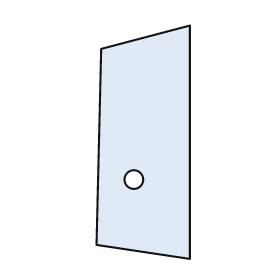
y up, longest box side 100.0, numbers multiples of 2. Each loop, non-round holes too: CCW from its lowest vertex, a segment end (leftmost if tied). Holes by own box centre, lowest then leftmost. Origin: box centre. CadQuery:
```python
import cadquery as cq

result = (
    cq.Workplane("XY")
    .moveTo(20.0, -50.0)
    .lineTo(20.0, 50.0)
    .lineTo(-18.0, 40.0)
    .lineTo(-20.0, -44.0)
    .close()
    .moveTo(-4.0, -16.0)
    .circle(4.0)
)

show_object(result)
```